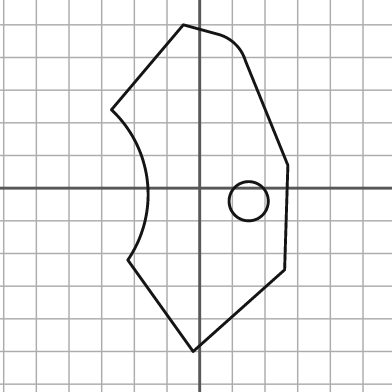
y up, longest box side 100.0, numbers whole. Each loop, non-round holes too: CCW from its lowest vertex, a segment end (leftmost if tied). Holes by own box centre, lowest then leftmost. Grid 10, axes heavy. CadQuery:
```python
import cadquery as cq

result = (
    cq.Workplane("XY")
    .moveTo(-2.0, -50.0)
    .lineTo(26.0, -25.0)
    .lineTo(27.0, 7.0)
    .lineTo(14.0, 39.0)
    .threePointArc((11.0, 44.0), (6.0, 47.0))
    .lineTo(-5.0, 50.0)
    .lineTo(-27.0, 24.0)
    .threePointArc((-16.0, 2.0), (-22.0, -22.0))
    .close()
    .moveTo(15.0, -4.0)
    .circle(6.0)
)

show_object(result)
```